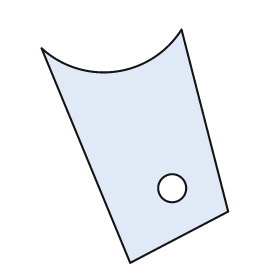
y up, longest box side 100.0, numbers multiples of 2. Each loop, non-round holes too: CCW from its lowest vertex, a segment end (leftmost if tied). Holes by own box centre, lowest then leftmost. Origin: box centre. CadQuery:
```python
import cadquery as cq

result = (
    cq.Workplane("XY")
    .moveTo(-2.0, -50.0)
    .lineTo(40.0, -28.0)
    .lineTo(20.0, 50.0)
    .threePointArc((-8.0, 32.0), (-40.0, 42.0))
    .close()
    .moveTo(16.0, -18.0)
    .circle(6.0)
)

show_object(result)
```